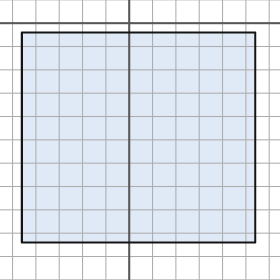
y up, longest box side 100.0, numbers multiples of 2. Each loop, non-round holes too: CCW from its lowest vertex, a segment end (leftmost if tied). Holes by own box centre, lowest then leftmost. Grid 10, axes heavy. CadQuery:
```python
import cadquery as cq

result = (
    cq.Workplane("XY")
    .moveTo(-46.0, -94.0)
    .lineTo(54.0, -94.0)
    .lineTo(54.0, -4.0)
    .lineTo(-46.0, -4.0)
    .close()
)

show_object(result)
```